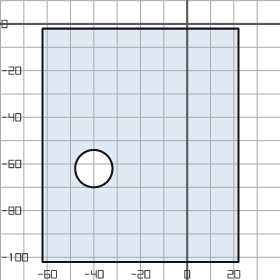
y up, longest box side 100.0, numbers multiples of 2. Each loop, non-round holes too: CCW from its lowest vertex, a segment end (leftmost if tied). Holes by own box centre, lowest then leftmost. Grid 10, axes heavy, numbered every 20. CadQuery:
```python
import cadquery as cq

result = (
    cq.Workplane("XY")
    .moveTo(-62.0, -102.0)
    .lineTo(22.0, -102.0)
    .lineTo(22.0, -2.0)
    .lineTo(-62.0, -2.0)
    .close()
    .moveTo(-40.0, -62.0)
    .circle(8.0)
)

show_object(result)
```